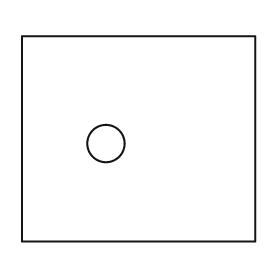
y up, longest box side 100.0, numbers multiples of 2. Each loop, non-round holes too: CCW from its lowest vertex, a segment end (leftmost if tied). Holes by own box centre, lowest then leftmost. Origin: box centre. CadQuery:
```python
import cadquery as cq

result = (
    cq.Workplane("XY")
    .moveTo(-50.0, -44.0)
    .lineTo(50.0, -44.0)
    .lineTo(50.0, 44.0)
    .lineTo(-50.0, 44.0)
    .close()
    .moveTo(-14.0, -2.0)
    .circle(8.0)
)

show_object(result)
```